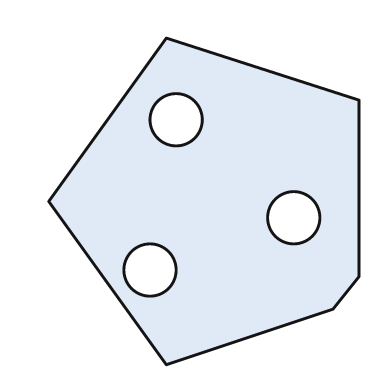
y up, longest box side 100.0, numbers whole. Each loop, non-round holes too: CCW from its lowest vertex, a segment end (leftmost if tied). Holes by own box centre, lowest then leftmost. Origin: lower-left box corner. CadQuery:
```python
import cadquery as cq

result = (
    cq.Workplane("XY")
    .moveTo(36.0, 0.0)
    .lineTo(87.0, 17.0)
    .lineTo(95.0, 27.0)
    .lineTo(95.0, 81.0)
    .lineTo(36.0, 100.0)
    .lineTo(0.0, 50.0)
    .close()
    .moveTo(31.0, 29.0)
    .circle(8.0)
    .moveTo(75.0, 45.0)
    .circle(8.0)
    .moveTo(39.0, 75.0)
    .circle(8.0)
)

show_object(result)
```